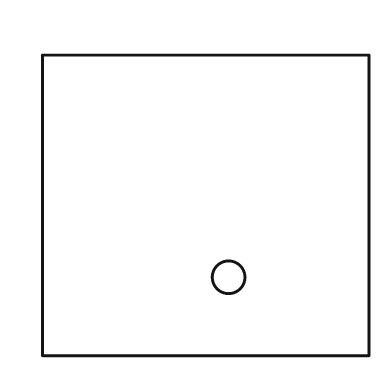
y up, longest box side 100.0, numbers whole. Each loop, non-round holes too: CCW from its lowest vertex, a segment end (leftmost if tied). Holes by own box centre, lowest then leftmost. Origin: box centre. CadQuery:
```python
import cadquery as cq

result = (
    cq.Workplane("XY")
    .moveTo(-50.0, -46.0)
    .lineTo(50.0, -46.0)
    .lineTo(50.0, 46.0)
    .lineTo(-50.0, 46.0)
    .close()
    .moveTo(7.0, -22.0)
    .circle(5.0)
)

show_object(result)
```